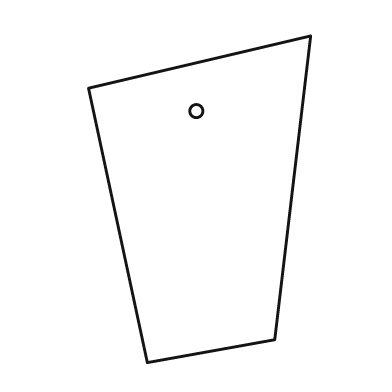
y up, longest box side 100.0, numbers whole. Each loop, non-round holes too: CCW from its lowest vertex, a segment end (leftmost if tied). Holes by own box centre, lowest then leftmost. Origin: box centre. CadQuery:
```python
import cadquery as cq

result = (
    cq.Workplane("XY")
    .moveTo(-16.0, -50.0)
    .lineTo(23.0, -43.0)
    .lineTo(34.0, 50.0)
    .lineTo(-34.0, 34.0)
    .close()
    .moveTo(-1.0, 27.0)
    .circle(2.0)
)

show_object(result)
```